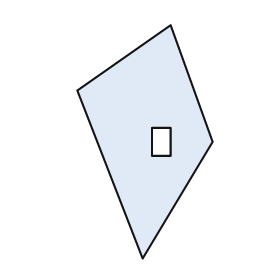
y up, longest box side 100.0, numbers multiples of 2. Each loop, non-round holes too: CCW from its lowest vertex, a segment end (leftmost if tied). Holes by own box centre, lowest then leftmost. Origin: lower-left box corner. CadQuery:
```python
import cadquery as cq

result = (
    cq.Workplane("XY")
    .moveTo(28.0, 0.0)
    .lineTo(58.0, 50.0)
    .lineTo(40.0, 100.0)
    .lineTo(0.0, 72.0)
    .close()
    .moveTo(32.0, 44.0)
    .lineTo(40.0, 44.0)
    .lineTo(40.0, 56.0)
    .lineTo(32.0, 56.0)
    .close()
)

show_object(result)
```